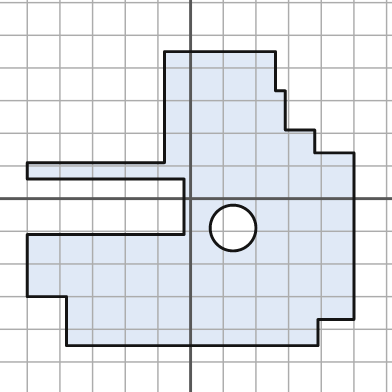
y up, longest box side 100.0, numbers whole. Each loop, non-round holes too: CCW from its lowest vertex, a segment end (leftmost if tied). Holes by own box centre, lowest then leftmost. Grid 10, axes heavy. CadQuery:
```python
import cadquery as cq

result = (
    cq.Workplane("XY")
    .moveTo(-38.0, -45.0)
    .lineTo(39.0, -45.0)
    .lineTo(39.0, -37.0)
    .lineTo(50.0, -37.0)
    .lineTo(50.0, 14.0)
    .lineTo(38.0, 14.0)
    .lineTo(38.0, 21.0)
    .lineTo(29.0, 21.0)
    .lineTo(29.0, 33.0)
    .lineTo(26.0, 33.0)
    .lineTo(26.0, 45.0)
    .lineTo(-8.0, 45.0)
    .lineTo(-8.0, 11.0)
    .lineTo(-50.0, 11.0)
    .lineTo(-50.0, 6.0)
    .lineTo(-2.0, 6.0)
    .lineTo(-2.0, -11.0)
    .lineTo(-50.0, -11.0)
    .lineTo(-50.0, -30.0)
    .lineTo(-38.0, -30.0)
    .close()
    .moveTo(13.0, -9.0)
    .circle(7.0)
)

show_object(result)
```